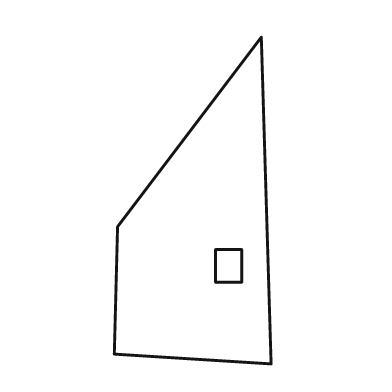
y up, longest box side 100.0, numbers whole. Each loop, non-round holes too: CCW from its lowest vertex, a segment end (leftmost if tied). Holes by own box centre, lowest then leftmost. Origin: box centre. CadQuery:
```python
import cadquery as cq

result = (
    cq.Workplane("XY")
    .moveTo(24.0, -50.0)
    .lineTo(21.0, 50.0)
    .lineTo(-23.0, -8.0)
    .lineTo(-24.0, -47.0)
    .close()
    .moveTo(7.0, -25.0)
    .lineTo(15.0, -25.0)
    .lineTo(15.0, -15.0)
    .lineTo(7.0, -15.0)
    .close()
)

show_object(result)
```